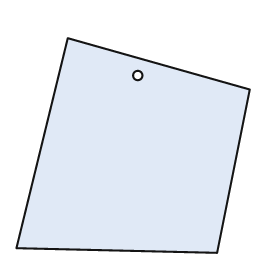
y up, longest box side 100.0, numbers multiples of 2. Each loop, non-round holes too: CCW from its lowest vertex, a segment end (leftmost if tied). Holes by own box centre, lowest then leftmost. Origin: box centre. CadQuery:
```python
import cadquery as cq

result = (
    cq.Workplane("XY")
    .moveTo(36.0, -46.0)
    .lineTo(50.0, 24.0)
    .lineTo(-28.0, 46.0)
    .lineTo(-50.0, -44.0)
    .close()
    .moveTo(2.0, 30.0)
    .circle(2.0)
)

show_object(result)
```